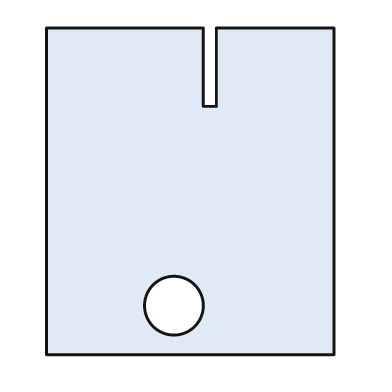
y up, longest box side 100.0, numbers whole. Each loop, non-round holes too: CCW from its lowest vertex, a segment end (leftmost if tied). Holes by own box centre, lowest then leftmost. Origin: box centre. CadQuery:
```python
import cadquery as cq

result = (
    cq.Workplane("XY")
    .moveTo(-44.0, -50.0)
    .lineTo(44.0, -50.0)
    .lineTo(44.0, 50.0)
    .lineTo(8.0, 50.0)
    .lineTo(8.0, 26.0)
    .lineTo(4.0, 26.0)
    .lineTo(4.0, 50.0)
    .lineTo(-44.0, 50.0)
    .close()
    .moveTo(-5.0, -35.0)
    .circle(9.0)
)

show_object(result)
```